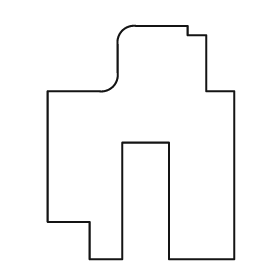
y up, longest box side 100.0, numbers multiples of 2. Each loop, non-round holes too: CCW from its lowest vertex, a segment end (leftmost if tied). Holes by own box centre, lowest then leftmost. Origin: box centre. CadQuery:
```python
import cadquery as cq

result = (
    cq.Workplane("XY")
    .moveTo(-22.0, -50.0)
    .lineTo(-8.0, -50.0)
    .lineTo(-8.0, 0.0)
    .lineTo(12.0, 0.0)
    .lineTo(12.0, -50.0)
    .lineTo(40.0, -50.0)
    .lineTo(40.0, 22.0)
    .lineTo(28.0, 22.0)
    .lineTo(28.0, 46.0)
    .lineTo(20.0, 46.0)
    .lineTo(20.0, 50.0)
    .lineTo(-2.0, 50.0)
    .threePointArc((-8.0, 48.0), (-10.0, 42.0))
    .lineTo(-10.0, 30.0)
    .threePointArc((-12.0, 24.0), (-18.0, 22.0))
    .lineTo(-40.0, 22.0)
    .lineTo(-40.0, -34.0)
    .lineTo(-22.0, -34.0)
    .close()
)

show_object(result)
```